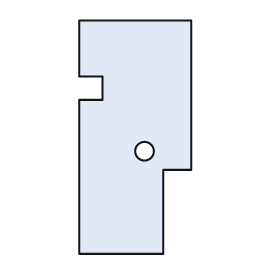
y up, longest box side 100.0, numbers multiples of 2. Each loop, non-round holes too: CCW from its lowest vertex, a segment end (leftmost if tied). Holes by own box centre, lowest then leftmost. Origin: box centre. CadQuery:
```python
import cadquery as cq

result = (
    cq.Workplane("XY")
    .moveTo(-24.0, -50.0)
    .lineTo(12.0, -50.0)
    .lineTo(12.0, -14.0)
    .lineTo(24.0, -14.0)
    .lineTo(24.0, 50.0)
    .lineTo(-24.0, 50.0)
    .lineTo(-24.0, 26.0)
    .lineTo(-14.0, 26.0)
    .lineTo(-14.0, 16.0)
    .lineTo(-24.0, 16.0)
    .close()
    .moveTo(4.0, -6.0)
    .circle(4.0)
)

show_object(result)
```